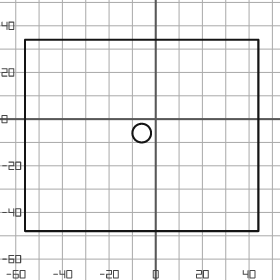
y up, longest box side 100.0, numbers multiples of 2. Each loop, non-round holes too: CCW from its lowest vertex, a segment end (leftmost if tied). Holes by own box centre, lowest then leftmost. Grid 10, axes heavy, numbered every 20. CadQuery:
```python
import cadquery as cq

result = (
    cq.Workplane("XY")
    .moveTo(-56.0, -48.0)
    .lineTo(44.0, -48.0)
    .lineTo(44.0, 34.0)
    .lineTo(-56.0, 34.0)
    .close()
    .moveTo(-6.0, -6.0)
    .circle(4.0)
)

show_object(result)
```